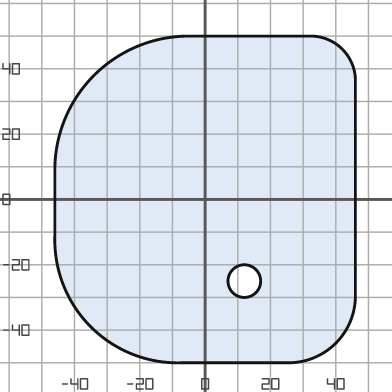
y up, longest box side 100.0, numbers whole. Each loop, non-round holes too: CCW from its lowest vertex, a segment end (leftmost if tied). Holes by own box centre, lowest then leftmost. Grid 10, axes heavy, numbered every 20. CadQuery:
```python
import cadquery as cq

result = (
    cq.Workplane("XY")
    .moveTo(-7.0, -50.0)
    .lineTo(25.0, -50.0)
    .threePointArc((40.0, -44.0), (46.0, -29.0))
    .lineTo(46.0, 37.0)
    .threePointArc((42.0, 46.0), (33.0, 50.0))
    .lineTo(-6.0, 50.0)
    .threePointArc((-34.0, 38.0), (-46.0, 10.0))
    .lineTo(-46.0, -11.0)
    .threePointArc((-35.0, -39.0), (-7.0, -50.0))
    .close()
    .moveTo(12.0, -25.0)
    .circle(5.0)
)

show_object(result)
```